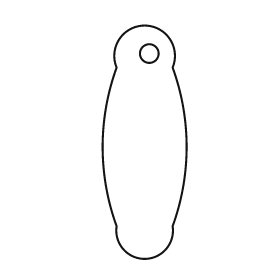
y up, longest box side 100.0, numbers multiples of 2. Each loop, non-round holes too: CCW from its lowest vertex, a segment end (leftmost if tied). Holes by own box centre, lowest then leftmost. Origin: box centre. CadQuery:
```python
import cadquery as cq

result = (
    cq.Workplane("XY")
    .moveTo(-12.0, -36.0)
    .threePointArc((0.0, -50.0), (12.0, -36.0))
    .threePointArc((18.0, -2.0), (12.0, 32.0))
    .threePointArc((0.0, 50.0), (-12.0, 32.0))
    .threePointArc((-18.0, -2.0), (-12.0, -36.0))
    .close()
    .moveTo(2.0, 38.0)
    .circle(4.0)
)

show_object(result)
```